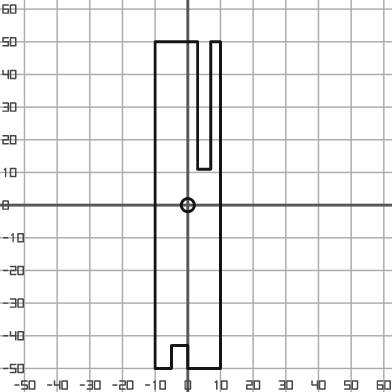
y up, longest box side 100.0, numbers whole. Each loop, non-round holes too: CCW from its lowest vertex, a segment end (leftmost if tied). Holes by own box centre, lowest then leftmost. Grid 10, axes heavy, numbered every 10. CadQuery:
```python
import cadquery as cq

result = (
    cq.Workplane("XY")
    .moveTo(-10.0, -50.0)
    .lineTo(-5.0, -50.0)
    .lineTo(-5.0, -43.0)
    .lineTo(0.0, -43.0)
    .lineTo(0.0, -50.0)
    .lineTo(10.0, -50.0)
    .lineTo(10.0, 50.0)
    .lineTo(7.0, 50.0)
    .lineTo(7.0, 11.0)
    .lineTo(3.0, 11.0)
    .lineTo(3.0, 50.0)
    .lineTo(-10.0, 50.0)
    .close()
    .moveTo(0.0, 0.0)
    .circle(2.0)
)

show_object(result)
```